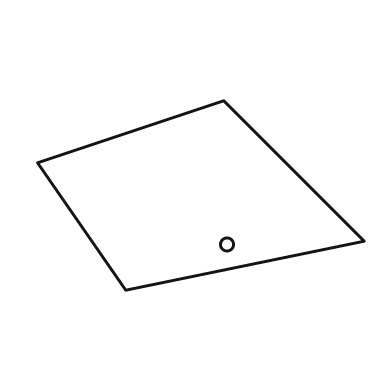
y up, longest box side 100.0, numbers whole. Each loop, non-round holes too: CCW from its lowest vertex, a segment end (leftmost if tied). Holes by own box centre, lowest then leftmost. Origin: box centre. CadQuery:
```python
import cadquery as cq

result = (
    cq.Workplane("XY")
    .moveTo(-23.0, -29.0)
    .lineTo(50.0, -14.0)
    .lineTo(7.0, 29.0)
    .lineTo(-50.0, 10.0)
    .close()
    .moveTo(8.0, -15.0)
    .circle(2.0)
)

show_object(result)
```